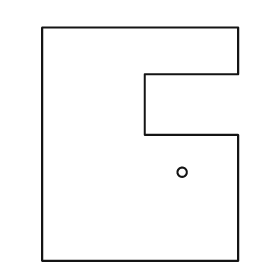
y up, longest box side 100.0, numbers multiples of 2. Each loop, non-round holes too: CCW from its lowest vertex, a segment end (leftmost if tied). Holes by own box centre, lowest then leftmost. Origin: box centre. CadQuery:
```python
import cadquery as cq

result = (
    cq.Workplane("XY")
    .moveTo(-42.0, -50.0)
    .lineTo(42.0, -50.0)
    .lineTo(42.0, 4.0)
    .lineTo(2.0, 4.0)
    .lineTo(2.0, 30.0)
    .lineTo(42.0, 30.0)
    .lineTo(42.0, 50.0)
    .lineTo(-42.0, 50.0)
    .close()
    .moveTo(18.0, -12.0)
    .circle(2.0)
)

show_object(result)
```